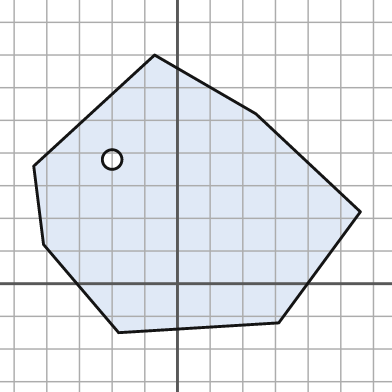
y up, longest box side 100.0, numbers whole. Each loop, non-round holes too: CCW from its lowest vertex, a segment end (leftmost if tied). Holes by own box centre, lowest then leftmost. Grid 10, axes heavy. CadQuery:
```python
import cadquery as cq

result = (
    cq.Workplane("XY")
    .moveTo(-18.0, -15.0)
    .lineTo(31.0, -12.0)
    .lineTo(56.0, 22.0)
    .lineTo(24.0, 52.0)
    .lineTo(-7.0, 70.0)
    .lineTo(-44.0, 36.0)
    .lineTo(-41.0, 12.0)
    .close()
    .moveTo(-20.0, 38.0)
    .circle(3.0)
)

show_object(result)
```